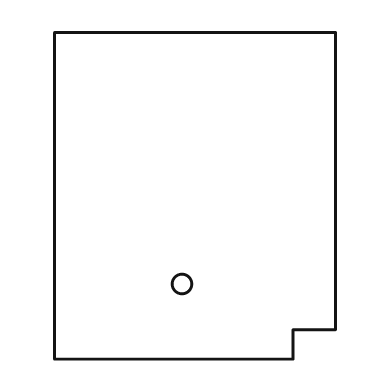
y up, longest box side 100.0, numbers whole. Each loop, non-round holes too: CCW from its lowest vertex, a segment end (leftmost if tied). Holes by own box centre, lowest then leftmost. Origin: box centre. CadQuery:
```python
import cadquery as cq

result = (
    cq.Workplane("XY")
    .moveTo(-43.0, -50.0)
    .lineTo(30.0, -50.0)
    .lineTo(30.0, -41.0)
    .lineTo(43.0, -41.0)
    .lineTo(43.0, 50.0)
    .lineTo(-43.0, 50.0)
    .close()
    .moveTo(-4.0, -27.0)
    .circle(3.0)
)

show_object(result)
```